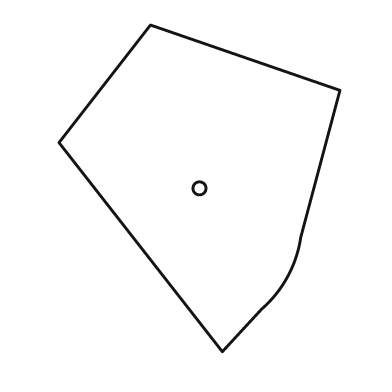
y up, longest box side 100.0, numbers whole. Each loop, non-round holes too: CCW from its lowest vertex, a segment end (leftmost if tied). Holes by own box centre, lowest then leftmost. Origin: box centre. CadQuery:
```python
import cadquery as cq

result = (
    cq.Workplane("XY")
    .moveTo(7.0, -50.0)
    .lineTo(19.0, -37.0)
    .threePointArc((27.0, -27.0), (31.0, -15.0))
    .lineTo(43.0, 30.0)
    .lineTo(-15.0, 50.0)
    .lineTo(-43.0, 14.0)
    .close()
    .moveTo(0.0, 0.0)
    .circle(2.0)
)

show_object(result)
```